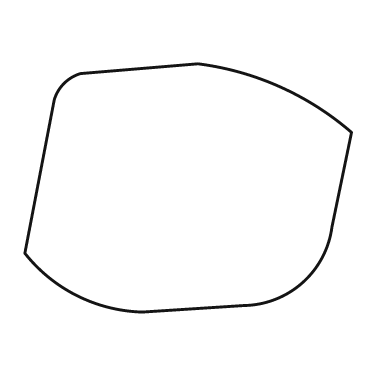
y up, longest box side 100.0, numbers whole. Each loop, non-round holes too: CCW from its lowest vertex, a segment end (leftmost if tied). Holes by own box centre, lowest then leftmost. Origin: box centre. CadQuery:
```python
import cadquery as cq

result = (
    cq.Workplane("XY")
    .moveTo(-14.0, -38.0)
    .lineTo(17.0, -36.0)
    .threePointArc((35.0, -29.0), (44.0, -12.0))
    .lineTo(50.0, 17.0)
    .threePointArc((28.0, 31.0), (3.0, 38.0))
    .lineTo(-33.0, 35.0)
    .threePointArc((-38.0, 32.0), (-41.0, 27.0))
    .lineTo(-50.0, -20.0)
    .threePointArc((-34.0, -33.0), (-14.0, -38.0))
    .close()
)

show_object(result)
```